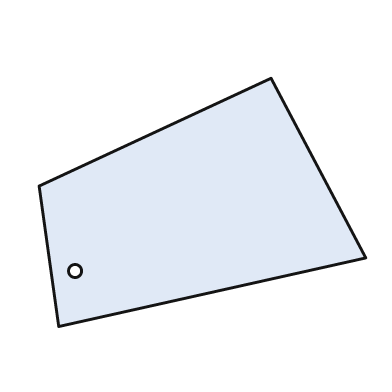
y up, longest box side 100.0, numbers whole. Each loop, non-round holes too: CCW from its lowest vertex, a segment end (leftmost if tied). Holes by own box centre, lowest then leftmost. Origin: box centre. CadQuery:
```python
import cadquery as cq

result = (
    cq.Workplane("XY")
    .moveTo(-44.0, -38.0)
    .lineTo(50.0, -17.0)
    .lineTo(21.0, 38.0)
    .lineTo(-50.0, 5.0)
    .close()
    .moveTo(-39.0, -21.0)
    .circle(2.0)
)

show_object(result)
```